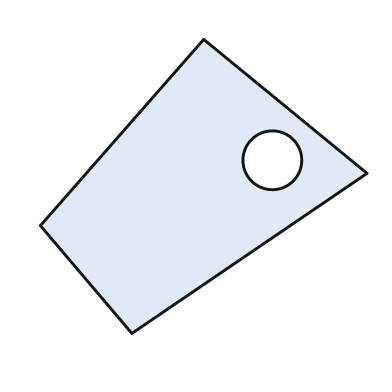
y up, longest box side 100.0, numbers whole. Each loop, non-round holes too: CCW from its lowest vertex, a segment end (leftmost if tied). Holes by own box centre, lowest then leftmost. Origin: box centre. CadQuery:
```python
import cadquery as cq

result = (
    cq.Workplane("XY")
    .moveTo(-22.0, -45.0)
    .lineTo(50.0, 4.0)
    .lineTo(0.0, 45.0)
    .lineTo(-50.0, -12.0)
    .close()
    .moveTo(21.0, 8.0)
    .circle(9.0)
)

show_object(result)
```